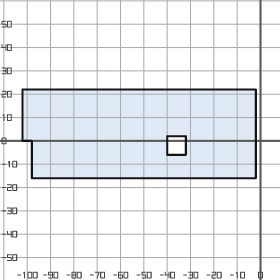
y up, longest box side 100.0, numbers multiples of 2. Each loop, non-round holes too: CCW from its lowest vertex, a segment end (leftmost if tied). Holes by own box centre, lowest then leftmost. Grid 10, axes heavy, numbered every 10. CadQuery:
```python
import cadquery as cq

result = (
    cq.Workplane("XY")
    .moveTo(-98.0, -16.0)
    .lineTo(-2.0, -16.0)
    .lineTo(-2.0, 22.0)
    .lineTo(-102.0, 22.0)
    .lineTo(-102.0, 0.0)
    .lineTo(-98.0, 0.0)
    .close()
    .moveTo(-40.0, -6.0)
    .lineTo(-32.0, -6.0)
    .lineTo(-32.0, 2.0)
    .lineTo(-40.0, 2.0)
    .close()
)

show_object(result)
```